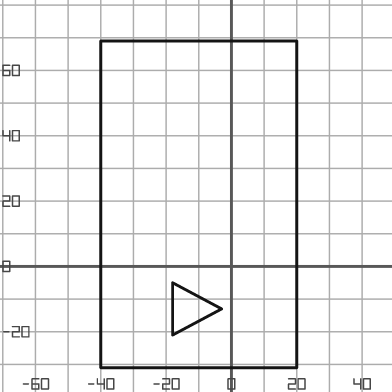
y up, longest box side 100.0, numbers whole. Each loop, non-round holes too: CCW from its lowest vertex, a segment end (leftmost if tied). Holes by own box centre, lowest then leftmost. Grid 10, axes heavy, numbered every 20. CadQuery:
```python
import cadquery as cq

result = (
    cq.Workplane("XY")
    .moveTo(-40.0, -31.0)
    .lineTo(20.0, -31.0)
    .lineTo(20.0, 69.0)
    .lineTo(-40.0, 69.0)
    .close()
    .moveTo(-18.0, -21.0)
    .lineTo(-3.0, -13.0)
    .lineTo(-18.0, -5.0)
    .close()
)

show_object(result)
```